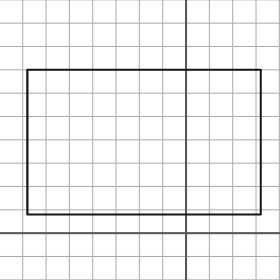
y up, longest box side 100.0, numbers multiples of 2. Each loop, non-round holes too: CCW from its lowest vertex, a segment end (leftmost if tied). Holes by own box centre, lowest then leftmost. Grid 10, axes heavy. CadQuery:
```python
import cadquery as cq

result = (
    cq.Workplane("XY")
    .moveTo(-68.0, 8.0)
    .lineTo(32.0, 8.0)
    .lineTo(32.0, 70.0)
    .lineTo(-68.0, 70.0)
    .close()
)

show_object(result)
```